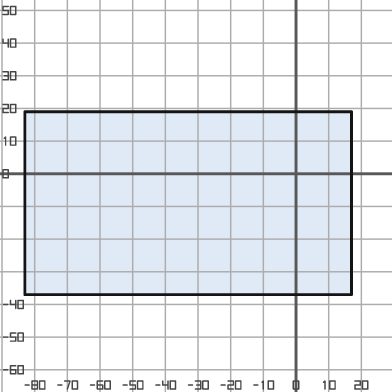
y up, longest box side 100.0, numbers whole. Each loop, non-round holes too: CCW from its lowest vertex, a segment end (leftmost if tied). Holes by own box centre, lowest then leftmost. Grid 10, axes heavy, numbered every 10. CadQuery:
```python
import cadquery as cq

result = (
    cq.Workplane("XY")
    .moveTo(-83.0, -37.0)
    .lineTo(17.0, -37.0)
    .lineTo(17.0, 19.0)
    .lineTo(-83.0, 19.0)
    .close()
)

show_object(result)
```